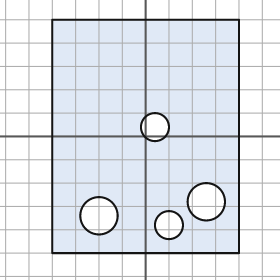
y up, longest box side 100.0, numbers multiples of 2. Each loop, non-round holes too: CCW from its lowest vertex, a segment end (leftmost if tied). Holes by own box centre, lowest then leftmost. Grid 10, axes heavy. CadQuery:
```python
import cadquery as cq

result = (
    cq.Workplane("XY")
    .moveTo(-40.0, -50.0)
    .lineTo(40.0, -50.0)
    .lineTo(40.0, 50.0)
    .lineTo(-40.0, 50.0)
    .close()
    .moveTo(10.0, -38.0)
    .circle(6.0)
    .moveTo(-20.0, -34.0)
    .circle(8.0)
    .moveTo(26.0, -28.0)
    .circle(8.0)
    .moveTo(4.0, 4.0)
    .circle(6.0)
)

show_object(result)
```